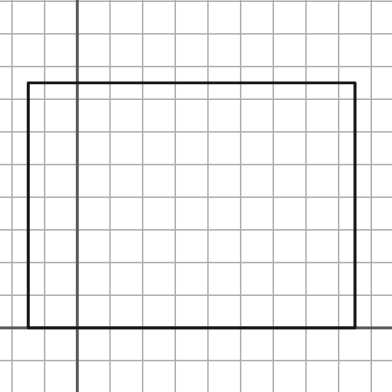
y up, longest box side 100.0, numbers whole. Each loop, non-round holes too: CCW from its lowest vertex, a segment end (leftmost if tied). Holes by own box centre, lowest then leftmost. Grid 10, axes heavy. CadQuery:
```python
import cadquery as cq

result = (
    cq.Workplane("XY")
    .moveTo(-15.0, 0.0)
    .lineTo(85.0, 0.0)
    .lineTo(85.0, 75.0)
    .lineTo(-15.0, 75.0)
    .close()
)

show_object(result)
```